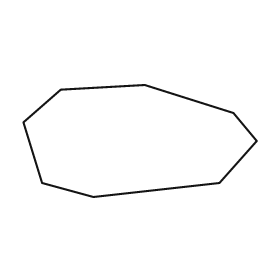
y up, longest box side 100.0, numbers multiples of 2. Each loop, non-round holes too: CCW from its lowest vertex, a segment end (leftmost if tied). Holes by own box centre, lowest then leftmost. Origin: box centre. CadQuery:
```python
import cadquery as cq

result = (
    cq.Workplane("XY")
    .moveTo(-20.0, -24.0)
    .lineTo(34.0, -18.0)
    .lineTo(50.0, 0.0)
    .lineTo(40.0, 12.0)
    .lineTo(2.0, 24.0)
    .lineTo(-34.0, 22.0)
    .lineTo(-50.0, 8.0)
    .lineTo(-42.0, -18.0)
    .close()
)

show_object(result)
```